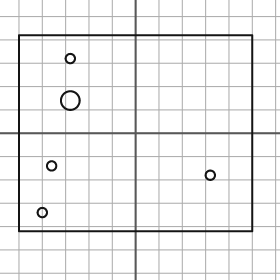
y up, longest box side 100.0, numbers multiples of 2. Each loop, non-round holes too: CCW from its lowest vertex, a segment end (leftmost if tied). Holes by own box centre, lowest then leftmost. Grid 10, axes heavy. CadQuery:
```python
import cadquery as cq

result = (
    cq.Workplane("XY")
    .moveTo(-50.0, -42.0)
    .lineTo(50.0, -42.0)
    .lineTo(50.0, 42.0)
    .lineTo(-50.0, 42.0)
    .close()
    .moveTo(-40.0, -34.0)
    .circle(2.0)
    .moveTo(32.0, -18.0)
    .circle(2.0)
    .moveTo(-36.0, -14.0)
    .circle(2.0)
    .moveTo(-28.0, 14.0)
    .circle(4.0)
    .moveTo(-28.0, 32.0)
    .circle(2.0)
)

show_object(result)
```